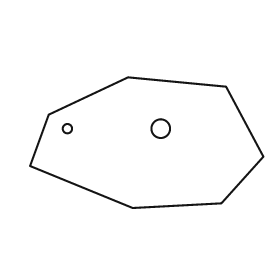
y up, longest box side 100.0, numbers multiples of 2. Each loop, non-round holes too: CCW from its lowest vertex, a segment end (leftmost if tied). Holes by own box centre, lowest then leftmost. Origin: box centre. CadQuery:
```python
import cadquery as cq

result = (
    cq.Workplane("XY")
    .moveTo(-6.0, -28.0)
    .lineTo(32.0, -26.0)
    .lineTo(50.0, -6.0)
    .lineTo(34.0, 24.0)
    .lineTo(-8.0, 28.0)
    .lineTo(-42.0, 12.0)
    .lineTo(-50.0, -10.0)
    .close()
    .moveTo(-34.0, 6.0)
    .circle(2.0)
    .moveTo(6.0, 6.0)
    .circle(4.0)
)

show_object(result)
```